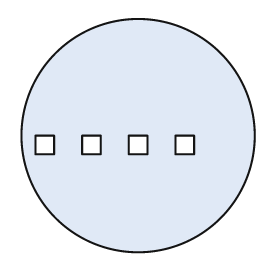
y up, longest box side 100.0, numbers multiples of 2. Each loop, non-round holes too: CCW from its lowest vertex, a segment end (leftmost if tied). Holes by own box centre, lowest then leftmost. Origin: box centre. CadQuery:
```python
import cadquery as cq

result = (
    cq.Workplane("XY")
    .moveTo(0.0, 0.0)
    .circle(50.0)
    .moveTo(-44.0, -8.0)
    .lineTo(-36.0, -8.0)
    .lineTo(-36.0, 0.0)
    .lineTo(-44.0, 0.0)
    .close()
    .moveTo(-24.0, -8.0)
    .lineTo(-16.0, -8.0)
    .lineTo(-16.0, 0.0)
    .lineTo(-24.0, 0.0)
    .close()
    .moveTo(-4.0, -8.0)
    .lineTo(4.0, -8.0)
    .lineTo(4.0, 0.0)
    .lineTo(-4.0, 0.0)
    .close()
    .moveTo(16.0, -8.0)
    .lineTo(24.0, -8.0)
    .lineTo(24.0, 0.0)
    .lineTo(16.0, 0.0)
    .close()
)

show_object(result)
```